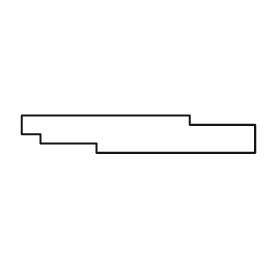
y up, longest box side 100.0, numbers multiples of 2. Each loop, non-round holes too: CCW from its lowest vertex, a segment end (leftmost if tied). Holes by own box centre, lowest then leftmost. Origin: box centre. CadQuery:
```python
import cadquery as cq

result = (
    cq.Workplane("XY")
    .moveTo(-18.0, -8.0)
    .lineTo(50.0, -8.0)
    .lineTo(50.0, 4.0)
    .lineTo(22.0, 4.0)
    .lineTo(22.0, 8.0)
    .lineTo(-50.0, 8.0)
    .lineTo(-50.0, 0.0)
    .lineTo(-42.0, 0.0)
    .lineTo(-42.0, -4.0)
    .lineTo(-18.0, -4.0)
    .close()
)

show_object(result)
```